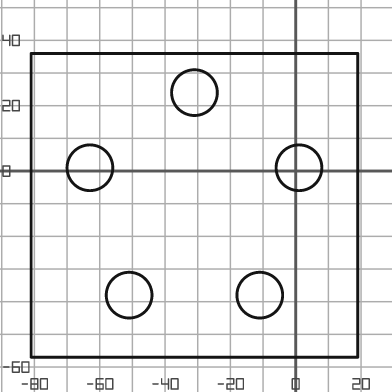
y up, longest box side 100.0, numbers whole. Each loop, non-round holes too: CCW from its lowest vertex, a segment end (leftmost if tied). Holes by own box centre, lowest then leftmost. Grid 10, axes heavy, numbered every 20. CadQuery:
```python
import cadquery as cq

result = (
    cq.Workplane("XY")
    .moveTo(-81.0, -57.0)
    .lineTo(19.0, -57.0)
    .lineTo(19.0, 36.0)
    .lineTo(-81.0, 36.0)
    .close()
    .moveTo(-51.0, -38.0)
    .circle(7.0)
    .moveTo(-11.0, -38.0)
    .circle(7.0)
    .moveTo(-63.0, 1.0)
    .circle(7.0)
    .moveTo(1.0, 1.0)
    .circle(7.0)
    .moveTo(-31.0, 24.0)
    .circle(7.0)
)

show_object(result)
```